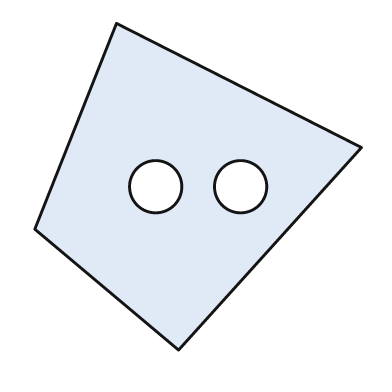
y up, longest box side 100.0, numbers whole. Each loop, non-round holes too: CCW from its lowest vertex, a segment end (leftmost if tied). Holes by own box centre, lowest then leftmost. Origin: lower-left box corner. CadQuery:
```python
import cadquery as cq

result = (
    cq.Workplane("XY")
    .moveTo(44.0, 0.0)
    .lineTo(100.0, 62.0)
    .lineTo(25.0, 100.0)
    .lineTo(0.0, 37.0)
    .close()
    .moveTo(37.0, 50.0)
    .circle(8.0)
    .moveTo(63.0, 50.0)
    .circle(8.0)
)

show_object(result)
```